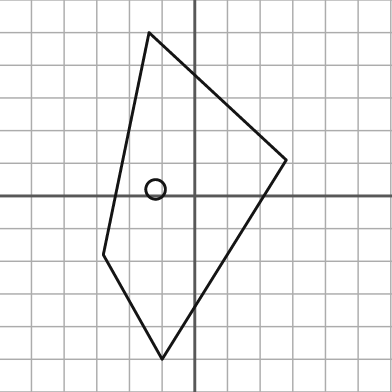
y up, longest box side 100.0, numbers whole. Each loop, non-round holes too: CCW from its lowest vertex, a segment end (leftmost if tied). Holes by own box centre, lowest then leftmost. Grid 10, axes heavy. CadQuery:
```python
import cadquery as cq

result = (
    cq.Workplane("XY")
    .moveTo(-10.0, -50.0)
    .lineTo(28.0, 11.0)
    .lineTo(-14.0, 50.0)
    .lineTo(-28.0, -18.0)
    .close()
    .moveTo(-12.0, 2.0)
    .circle(3.0)
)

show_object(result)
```